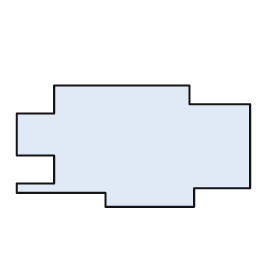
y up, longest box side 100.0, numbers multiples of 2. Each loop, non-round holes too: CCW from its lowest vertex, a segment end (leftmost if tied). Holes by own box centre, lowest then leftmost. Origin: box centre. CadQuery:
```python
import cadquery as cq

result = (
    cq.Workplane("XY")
    .moveTo(-12.0, -26.0)
    .lineTo(26.0, -26.0)
    .lineTo(26.0, -18.0)
    .lineTo(50.0, -18.0)
    .lineTo(50.0, 18.0)
    .lineTo(24.0, 18.0)
    .lineTo(24.0, 26.0)
    .lineTo(-34.0, 26.0)
    .lineTo(-34.0, 14.0)
    .lineTo(-50.0, 14.0)
    .lineTo(-50.0, -4.0)
    .lineTo(-34.0, -4.0)
    .lineTo(-34.0, -16.0)
    .lineTo(-50.0, -16.0)
    .lineTo(-50.0, -20.0)
    .lineTo(-12.0, -20.0)
    .close()
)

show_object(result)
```